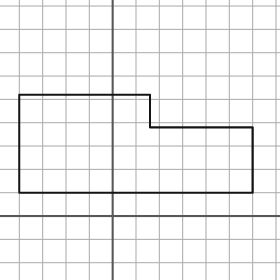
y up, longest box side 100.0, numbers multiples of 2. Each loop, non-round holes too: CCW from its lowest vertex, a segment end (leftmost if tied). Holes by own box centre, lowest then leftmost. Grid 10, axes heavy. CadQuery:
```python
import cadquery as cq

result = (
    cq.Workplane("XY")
    .moveTo(-40.0, 10.0)
    .lineTo(60.0, 10.0)
    .lineTo(60.0, 38.0)
    .lineTo(16.0, 38.0)
    .lineTo(16.0, 52.0)
    .lineTo(-40.0, 52.0)
    .close()
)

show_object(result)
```